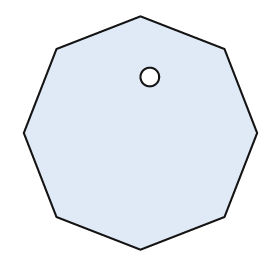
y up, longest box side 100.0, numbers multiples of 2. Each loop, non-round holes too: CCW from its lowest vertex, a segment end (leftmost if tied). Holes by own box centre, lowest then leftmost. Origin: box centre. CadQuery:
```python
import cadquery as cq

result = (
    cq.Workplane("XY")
    .moveTo(0.0, -50.0)
    .lineTo(36.0, -36.0)
    .lineTo(50.0, 0.0)
    .lineTo(36.0, 36.0)
    .lineTo(0.0, 50.0)
    .lineTo(-36.0, 36.0)
    .lineTo(-50.0, 0.0)
    .lineTo(-36.0, -36.0)
    .close()
    .moveTo(4.0, 24.0)
    .circle(4.0)
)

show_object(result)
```